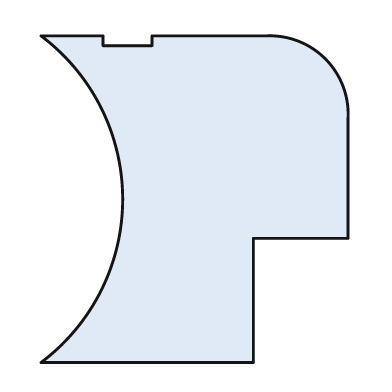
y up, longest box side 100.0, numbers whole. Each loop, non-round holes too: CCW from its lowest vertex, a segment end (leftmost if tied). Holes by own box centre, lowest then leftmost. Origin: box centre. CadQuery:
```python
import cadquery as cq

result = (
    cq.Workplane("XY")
    .moveTo(-47.0, -50.0)
    .lineTo(18.0, -50.0)
    .lineTo(18.0, -12.0)
    .lineTo(47.0, -12.0)
    .lineTo(47.0, 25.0)
    .threePointArc((40.0, 43.0), (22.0, 50.0))
    .lineTo(-13.0, 50.0)
    .lineTo(-13.0, 47.0)
    .lineTo(-28.0, 47.0)
    .lineTo(-28.0, 50.0)
    .lineTo(-47.0, 50.0)
    .threePointArc((-22.0, 0.0), (-47.0, -50.0))
    .close()
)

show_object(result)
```